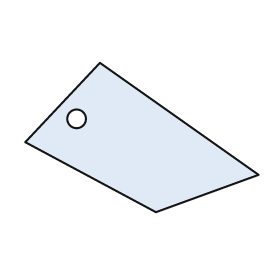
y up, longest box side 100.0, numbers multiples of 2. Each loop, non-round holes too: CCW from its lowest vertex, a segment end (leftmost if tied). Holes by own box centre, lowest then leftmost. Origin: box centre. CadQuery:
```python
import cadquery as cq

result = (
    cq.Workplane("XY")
    .moveTo(6.0, -32.0)
    .lineTo(50.0, -16.0)
    .lineTo(-18.0, 32.0)
    .lineTo(-50.0, -2.0)
    .close()
    .moveTo(-28.0, 8.0)
    .circle(4.0)
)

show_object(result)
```